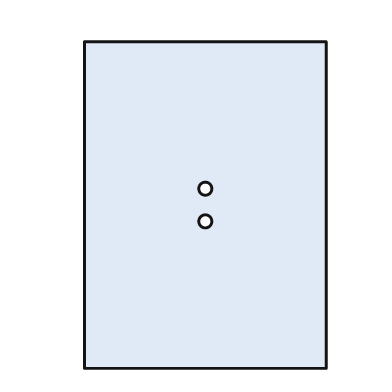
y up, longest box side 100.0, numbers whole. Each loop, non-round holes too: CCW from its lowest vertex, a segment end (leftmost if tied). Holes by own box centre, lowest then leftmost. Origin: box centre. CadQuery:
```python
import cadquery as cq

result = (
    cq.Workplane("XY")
    .moveTo(-37.0, -50.0)
    .lineTo(37.0, -50.0)
    .lineTo(37.0, 50.0)
    .lineTo(-37.0, 50.0)
    .close()
    .moveTo(0.0, -5.0)
    .circle(2.0)
    .moveTo(0.0, 5.0)
    .circle(2.0)
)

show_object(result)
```